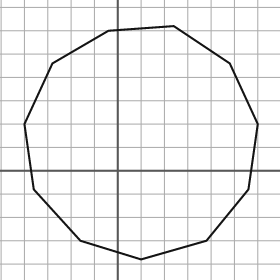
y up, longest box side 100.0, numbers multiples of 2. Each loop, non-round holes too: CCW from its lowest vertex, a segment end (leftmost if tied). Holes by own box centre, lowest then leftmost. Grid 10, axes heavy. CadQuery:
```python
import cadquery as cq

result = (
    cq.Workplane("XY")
    .moveTo(10.0, -38.0)
    .lineTo(38.0, -30.0)
    .lineTo(56.0, -8.0)
    .lineTo(60.0, 20.0)
    .lineTo(48.0, 46.0)
    .lineTo(24.0, 62.0)
    .lineTo(-4.0, 60.0)
    .lineTo(-28.0, 46.0)
    .lineTo(-40.0, 20.0)
    .lineTo(-36.0, -8.0)
    .lineTo(-16.0, -30.0)
    .close()
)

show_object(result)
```